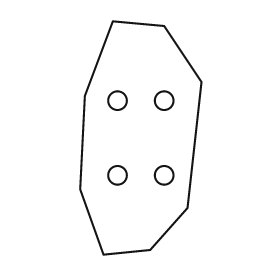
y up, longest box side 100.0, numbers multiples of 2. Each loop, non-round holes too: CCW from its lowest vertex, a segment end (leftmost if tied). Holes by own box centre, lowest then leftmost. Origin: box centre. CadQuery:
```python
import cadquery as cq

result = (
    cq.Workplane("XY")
    .moveTo(-16.0, -50.0)
    .lineTo(4.0, -48.0)
    .lineTo(20.0, -30.0)
    .lineTo(26.0, 24.0)
    .lineTo(10.0, 48.0)
    .lineTo(-12.0, 50.0)
    .lineTo(-24.0, 18.0)
    .lineTo(-26.0, -22.0)
    .close()
    .moveTo(-10.0, -16.0)
    .circle(4.0)
    .moveTo(10.0, -16.0)
    .circle(4.0)
    .moveTo(-10.0, 16.0)
    .circle(4.0)
    .moveTo(10.0, 16.0)
    .circle(4.0)
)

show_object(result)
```